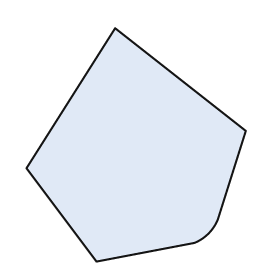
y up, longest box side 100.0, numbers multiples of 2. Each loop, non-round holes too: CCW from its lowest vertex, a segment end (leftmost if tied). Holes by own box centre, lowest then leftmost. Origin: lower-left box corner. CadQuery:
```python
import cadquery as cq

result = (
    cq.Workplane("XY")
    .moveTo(30.0, 0.0)
    .lineTo(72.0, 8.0)
    .threePointArc((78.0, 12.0), (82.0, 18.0))
    .lineTo(94.0, 56.0)
    .lineTo(38.0, 100.0)
    .lineTo(0.0, 40.0)
    .close()
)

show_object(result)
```